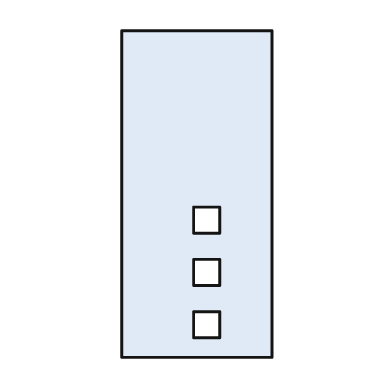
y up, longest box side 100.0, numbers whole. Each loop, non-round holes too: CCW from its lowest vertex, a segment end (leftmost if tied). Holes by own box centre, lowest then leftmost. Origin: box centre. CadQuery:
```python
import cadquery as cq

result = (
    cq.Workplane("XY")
    .moveTo(-23.0, -50.0)
    .lineTo(23.0, -50.0)
    .lineTo(23.0, 50.0)
    .lineTo(-23.0, 50.0)
    .close()
    .moveTo(-1.0, -44.0)
    .lineTo(7.0, -44.0)
    .lineTo(7.0, -36.0)
    .lineTo(-1.0, -36.0)
    .close()
    .moveTo(-1.0, -28.0)
    .lineTo(7.0, -28.0)
    .lineTo(7.0, -20.0)
    .lineTo(-1.0, -20.0)
    .close()
    .moveTo(-1.0, -12.0)
    .lineTo(7.0, -12.0)
    .lineTo(7.0, -4.0)
    .lineTo(-1.0, -4.0)
    .close()
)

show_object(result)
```